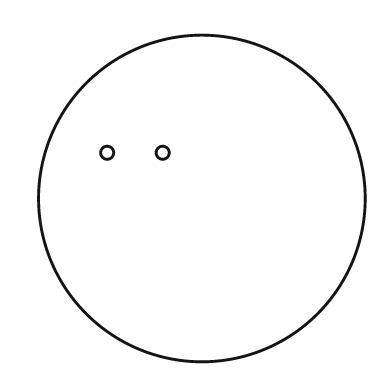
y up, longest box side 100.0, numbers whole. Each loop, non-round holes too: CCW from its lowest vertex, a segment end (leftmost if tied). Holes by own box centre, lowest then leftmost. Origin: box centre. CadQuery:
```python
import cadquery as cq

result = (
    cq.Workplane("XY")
    .moveTo(0.0, 0.0)
    .circle(50.0)
    .moveTo(-29.0, 14.0)
    .circle(2.0)
    .moveTo(-12.0, 14.0)
    .circle(2.0)
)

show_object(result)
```